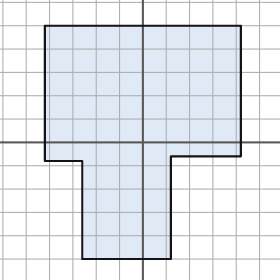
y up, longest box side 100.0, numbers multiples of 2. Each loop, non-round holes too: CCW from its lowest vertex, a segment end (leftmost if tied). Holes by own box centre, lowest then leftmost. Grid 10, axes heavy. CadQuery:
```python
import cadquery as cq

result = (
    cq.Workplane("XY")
    .moveTo(-26.0, -50.0)
    .lineTo(12.0, -50.0)
    .lineTo(12.0, -6.0)
    .lineTo(42.0, -6.0)
    .lineTo(42.0, 50.0)
    .lineTo(-42.0, 50.0)
    .lineTo(-42.0, -8.0)
    .lineTo(-26.0, -8.0)
    .close()
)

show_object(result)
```